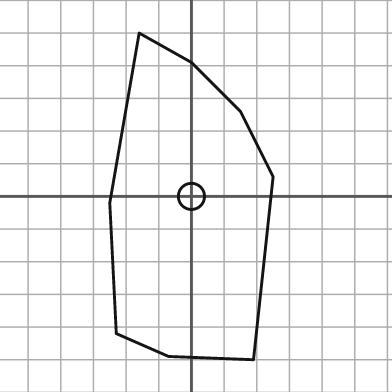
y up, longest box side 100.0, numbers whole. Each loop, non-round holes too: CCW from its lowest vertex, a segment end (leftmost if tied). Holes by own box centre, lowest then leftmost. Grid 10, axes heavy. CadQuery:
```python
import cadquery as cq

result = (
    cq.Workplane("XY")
    .moveTo(19.0, -50.0)
    .lineTo(25.0, 6.0)
    .lineTo(15.0, 26.0)
    .lineTo(0.0, 41.0)
    .lineTo(-16.0, 50.0)
    .lineTo(-25.0, -2.0)
    .lineTo(-23.0, -42.0)
    .lineTo(-7.0, -49.0)
    .close()
    .moveTo(0.0, 0.0)
    .circle(4.0)
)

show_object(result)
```